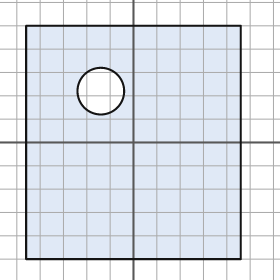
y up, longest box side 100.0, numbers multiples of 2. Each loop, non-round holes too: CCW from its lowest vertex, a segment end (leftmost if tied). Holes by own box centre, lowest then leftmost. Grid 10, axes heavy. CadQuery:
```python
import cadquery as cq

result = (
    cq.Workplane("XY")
    .moveTo(-46.0, -50.0)
    .lineTo(46.0, -50.0)
    .lineTo(46.0, 50.0)
    .lineTo(-46.0, 50.0)
    .close()
    .moveTo(-14.0, 22.0)
    .circle(10.0)
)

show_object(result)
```